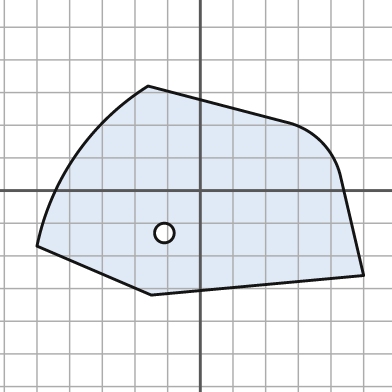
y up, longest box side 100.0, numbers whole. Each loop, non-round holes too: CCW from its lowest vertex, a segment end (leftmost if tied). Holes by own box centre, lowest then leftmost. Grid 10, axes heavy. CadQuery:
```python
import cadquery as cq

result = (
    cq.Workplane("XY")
    .moveTo(-15.0, -32.0)
    .lineTo(50.0, -26.0)
    .lineTo(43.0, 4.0)
    .threePointArc((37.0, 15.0), (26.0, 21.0))
    .lineTo(-16.0, 32.0)
    .threePointArc((-38.0, 11.0), (-50.0, -17.0))
    .close()
    .moveTo(-11.0, -13.0)
    .circle(3.0)
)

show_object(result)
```